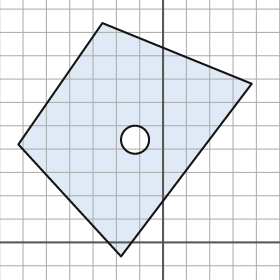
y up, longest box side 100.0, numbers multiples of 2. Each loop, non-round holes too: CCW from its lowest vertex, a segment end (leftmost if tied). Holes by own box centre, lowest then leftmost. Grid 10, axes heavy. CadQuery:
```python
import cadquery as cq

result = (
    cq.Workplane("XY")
    .moveTo(-18.0, -6.0)
    .lineTo(38.0, 68.0)
    .lineTo(-26.0, 94.0)
    .lineTo(-62.0, 42.0)
    .close()
    .moveTo(-12.0, 44.0)
    .circle(6.0)
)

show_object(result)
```